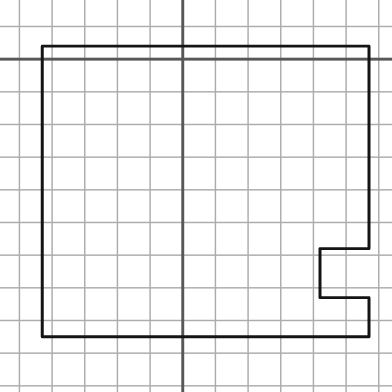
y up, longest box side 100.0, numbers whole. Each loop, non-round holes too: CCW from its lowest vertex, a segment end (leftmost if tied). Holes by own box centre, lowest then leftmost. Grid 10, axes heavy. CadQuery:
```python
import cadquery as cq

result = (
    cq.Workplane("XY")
    .moveTo(-43.0, -85.0)
    .lineTo(57.0, -85.0)
    .lineTo(57.0, -73.0)
    .lineTo(42.0, -73.0)
    .lineTo(42.0, -58.0)
    .lineTo(57.0, -58.0)
    .lineTo(57.0, 4.0)
    .lineTo(-43.0, 4.0)
    .close()
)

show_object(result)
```